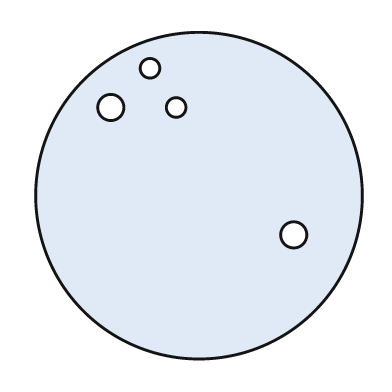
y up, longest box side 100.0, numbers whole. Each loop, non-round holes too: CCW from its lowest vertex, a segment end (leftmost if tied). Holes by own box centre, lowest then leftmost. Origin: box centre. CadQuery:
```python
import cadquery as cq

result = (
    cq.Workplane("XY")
    .moveTo(0.0, 0.0)
    .circle(50.0)
    .moveTo(29.0, -12.0)
    .circle(4.0)
    .moveTo(-27.0, 27.0)
    .circle(4.0)
    .moveTo(-7.0, 27.0)
    .circle(3.0)
    .moveTo(-15.0, 39.0)
    .circle(3.0)
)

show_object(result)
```